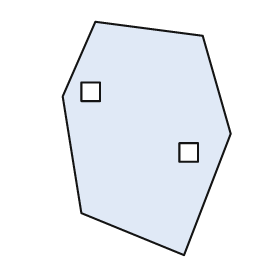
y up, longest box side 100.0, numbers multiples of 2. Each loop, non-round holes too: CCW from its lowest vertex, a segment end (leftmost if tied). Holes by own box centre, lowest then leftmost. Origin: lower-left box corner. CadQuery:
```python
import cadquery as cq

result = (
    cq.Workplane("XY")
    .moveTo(52.0, 0.0)
    .lineTo(72.0, 52.0)
    .lineTo(60.0, 94.0)
    .lineTo(14.0, 100.0)
    .lineTo(0.0, 68.0)
    .lineTo(8.0, 18.0)
    .close()
    .moveTo(50.0, 40.0)
    .lineTo(58.0, 40.0)
    .lineTo(58.0, 48.0)
    .lineTo(50.0, 48.0)
    .close()
    .moveTo(8.0, 66.0)
    .lineTo(16.0, 66.0)
    .lineTo(16.0, 74.0)
    .lineTo(8.0, 74.0)
    .close()
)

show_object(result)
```